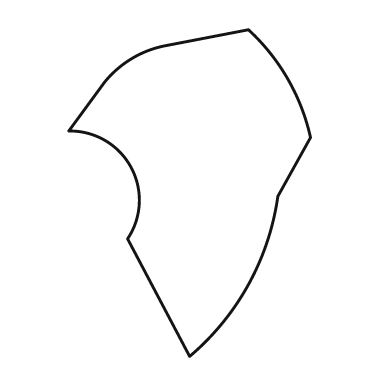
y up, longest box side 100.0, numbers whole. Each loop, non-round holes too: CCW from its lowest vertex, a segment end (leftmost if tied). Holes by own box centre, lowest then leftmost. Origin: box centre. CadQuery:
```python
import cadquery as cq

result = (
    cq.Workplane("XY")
    .moveTo(0.0, -50.0)
    .threePointArc((18.0, -28.0), (27.0, -1.0))
    .lineTo(37.0, 17.0)
    .threePointArc((30.0, 35.0), (18.0, 50.0))
    .lineTo(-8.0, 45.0)
    .threePointArc((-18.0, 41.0), (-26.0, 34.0))
    .lineTo(-37.0, 19.0)
    .threePointArc((-18.0, 8.0), (-19.0, -14.0))
    .close()
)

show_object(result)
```